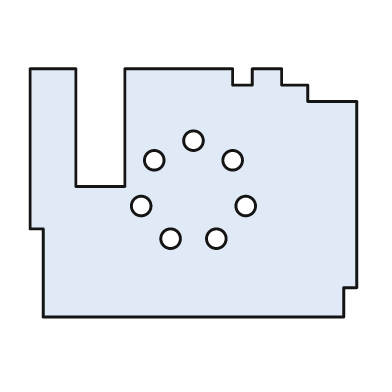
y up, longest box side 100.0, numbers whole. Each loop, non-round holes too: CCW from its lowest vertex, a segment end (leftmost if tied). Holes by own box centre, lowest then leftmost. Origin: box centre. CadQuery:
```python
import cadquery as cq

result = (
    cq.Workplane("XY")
    .moveTo(-46.0, -38.0)
    .lineTo(46.0, -38.0)
    .lineTo(46.0, -29.0)
    .lineTo(50.0, -29.0)
    .lineTo(50.0, 28.0)
    .lineTo(35.0, 28.0)
    .lineTo(35.0, 33.0)
    .lineTo(27.0, 33.0)
    .lineTo(27.0, 38.0)
    .lineTo(18.0, 38.0)
    .lineTo(18.0, 33.0)
    .lineTo(12.0, 33.0)
    .lineTo(12.0, 38.0)
    .lineTo(-21.0, 38.0)
    .lineTo(-21.0, 2.0)
    .lineTo(-36.0, 2.0)
    .lineTo(-36.0, 38.0)
    .lineTo(-50.0, 38.0)
    .lineTo(-50.0, -11.0)
    .lineTo(-46.0, -11.0)
    .close()
    .moveTo(-7.0, -14.0)
    .circle(3.0)
    .moveTo(7.0, -14.0)
    .circle(3.0)
    .moveTo(-16.0, -4.0)
    .circle(3.0)
    .moveTo(16.0, -4.0)
    .circle(3.0)
    .moveTo(-12.0, 10.0)
    .circle(3.0)
    .moveTo(12.0, 10.0)
    .circle(3.0)
    .moveTo(0.0, 16.0)
    .circle(3.0)
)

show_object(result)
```